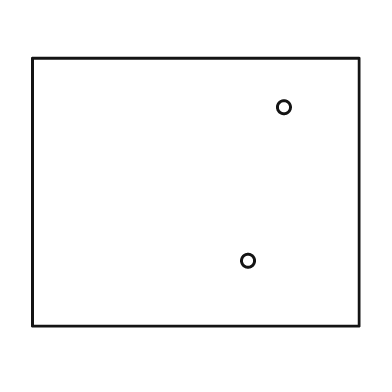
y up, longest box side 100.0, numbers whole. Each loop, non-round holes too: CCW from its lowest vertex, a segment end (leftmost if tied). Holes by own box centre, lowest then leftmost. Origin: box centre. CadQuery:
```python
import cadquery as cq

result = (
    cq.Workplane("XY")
    .moveTo(-50.0, -41.0)
    .lineTo(50.0, -41.0)
    .lineTo(50.0, 41.0)
    .lineTo(-50.0, 41.0)
    .close()
    .moveTo(16.0, -21.0)
    .circle(2.0)
    .moveTo(27.0, 26.0)
    .circle(2.0)
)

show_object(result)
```